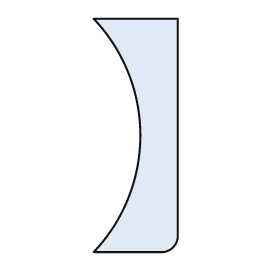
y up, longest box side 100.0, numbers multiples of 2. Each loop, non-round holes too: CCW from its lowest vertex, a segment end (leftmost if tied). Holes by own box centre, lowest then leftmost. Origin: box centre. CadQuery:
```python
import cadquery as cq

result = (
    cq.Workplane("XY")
    .moveTo(-18.0, -50.0)
    .lineTo(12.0, -50.0)
    .threePointArc((16.0, -48.0), (18.0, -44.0))
    .lineTo(18.0, 50.0)
    .lineTo(-18.0, 50.0)
    .threePointArc((2.0, 0.0), (-18.0, -50.0))
    .close()
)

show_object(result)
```